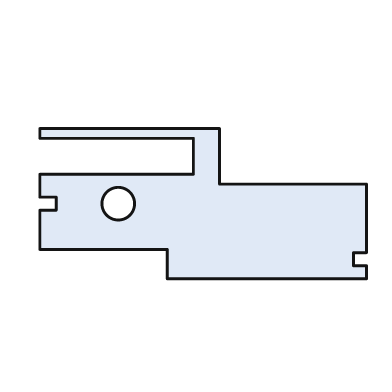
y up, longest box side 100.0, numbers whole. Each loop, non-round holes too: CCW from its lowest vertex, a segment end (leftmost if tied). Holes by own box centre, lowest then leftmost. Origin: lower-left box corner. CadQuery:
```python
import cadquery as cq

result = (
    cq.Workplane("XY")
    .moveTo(39.0, 0.0)
    .lineTo(100.0, 0.0)
    .lineTo(100.0, 4.0)
    .lineTo(96.0, 4.0)
    .lineTo(96.0, 8.0)
    .lineTo(100.0, 8.0)
    .lineTo(100.0, 29.0)
    .lineTo(55.0, 29.0)
    .lineTo(55.0, 46.0)
    .lineTo(0.0, 46.0)
    .lineTo(0.0, 43.0)
    .lineTo(47.0, 43.0)
    .lineTo(47.0, 32.0)
    .lineTo(0.0, 32.0)
    .lineTo(0.0, 25.0)
    .lineTo(5.0, 25.0)
    .lineTo(5.0, 21.0)
    .lineTo(0.0, 21.0)
    .lineTo(0.0, 9.0)
    .lineTo(39.0, 9.0)
    .close()
    .moveTo(24.0, 23.0)
    .circle(5.0)
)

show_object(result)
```